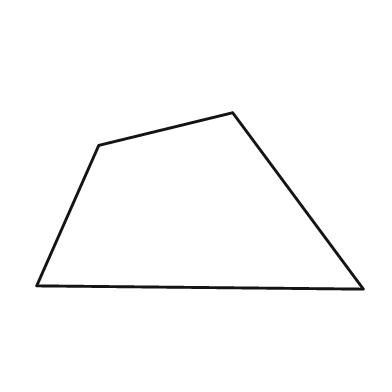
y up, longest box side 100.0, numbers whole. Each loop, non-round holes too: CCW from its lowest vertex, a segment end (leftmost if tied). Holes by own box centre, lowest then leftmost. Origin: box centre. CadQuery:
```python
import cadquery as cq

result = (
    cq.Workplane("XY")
    .moveTo(50.0, -27.0)
    .lineTo(10.0, 27.0)
    .lineTo(-31.0, 17.0)
    .lineTo(-50.0, -26.0)
    .close()
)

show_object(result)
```